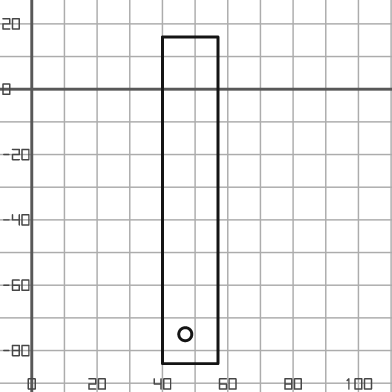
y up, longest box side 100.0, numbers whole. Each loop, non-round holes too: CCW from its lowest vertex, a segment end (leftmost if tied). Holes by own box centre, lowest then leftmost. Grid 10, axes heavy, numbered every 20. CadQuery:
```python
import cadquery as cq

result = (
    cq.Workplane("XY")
    .moveTo(40.0, -84.0)
    .lineTo(57.0, -84.0)
    .lineTo(57.0, 16.0)
    .lineTo(40.0, 16.0)
    .close()
    .moveTo(47.0, -75.0)
    .circle(2.0)
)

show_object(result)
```